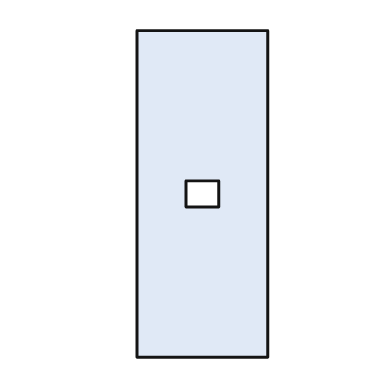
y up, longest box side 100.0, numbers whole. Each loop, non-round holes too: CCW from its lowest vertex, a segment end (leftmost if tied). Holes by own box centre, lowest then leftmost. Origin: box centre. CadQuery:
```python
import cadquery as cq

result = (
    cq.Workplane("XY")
    .moveTo(-20.0, -50.0)
    .lineTo(20.0, -50.0)
    .lineTo(20.0, 50.0)
    .lineTo(-20.0, 50.0)
    .close()
    .moveTo(-5.0, -4.0)
    .lineTo(5.0, -4.0)
    .lineTo(5.0, 4.0)
    .lineTo(-5.0, 4.0)
    .close()
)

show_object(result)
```